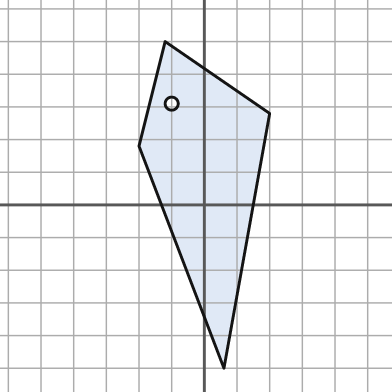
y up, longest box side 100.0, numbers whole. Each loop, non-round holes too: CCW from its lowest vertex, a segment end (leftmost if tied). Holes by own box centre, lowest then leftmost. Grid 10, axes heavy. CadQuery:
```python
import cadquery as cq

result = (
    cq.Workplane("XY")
    .moveTo(6.0, -50.0)
    .lineTo(20.0, 28.0)
    .lineTo(-12.0, 50.0)
    .lineTo(-20.0, 18.0)
    .close()
    .moveTo(-10.0, 31.0)
    .circle(2.0)
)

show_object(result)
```